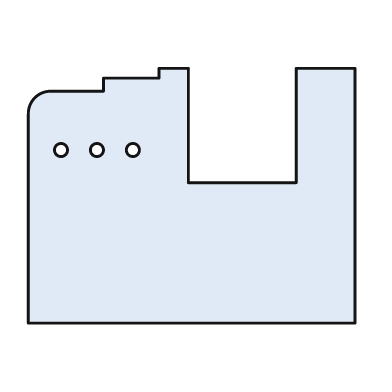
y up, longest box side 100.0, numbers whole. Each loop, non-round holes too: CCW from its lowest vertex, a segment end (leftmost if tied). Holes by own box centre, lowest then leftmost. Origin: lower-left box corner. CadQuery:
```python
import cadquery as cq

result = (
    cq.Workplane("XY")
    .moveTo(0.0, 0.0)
    .lineTo(100.0, 0.0)
    .lineTo(100.0, 78.0)
    .lineTo(82.0, 78.0)
    .lineTo(82.0, 43.0)
    .lineTo(49.0, 43.0)
    .lineTo(49.0, 78.0)
    .lineTo(40.0, 78.0)
    .lineTo(40.0, 75.0)
    .lineTo(23.0, 75.0)
    .lineTo(23.0, 71.0)
    .lineTo(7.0, 71.0)
    .threePointArc((2.0, 69.0), (0.0, 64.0))
    .close()
    .moveTo(10.0, 53.0)
    .circle(2.0)
    .moveTo(21.0, 53.0)
    .circle(2.0)
    .moveTo(32.0, 53.0)
    .circle(2.0)
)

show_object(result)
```